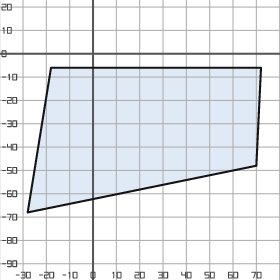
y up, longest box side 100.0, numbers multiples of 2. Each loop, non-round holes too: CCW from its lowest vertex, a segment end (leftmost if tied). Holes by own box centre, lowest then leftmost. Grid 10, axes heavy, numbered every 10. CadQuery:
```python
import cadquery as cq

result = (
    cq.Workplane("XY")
    .moveTo(-28.0, -68.0)
    .lineTo(70.0, -48.0)
    .lineTo(72.0, -6.0)
    .lineTo(-18.0, -6.0)
    .close()
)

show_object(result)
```